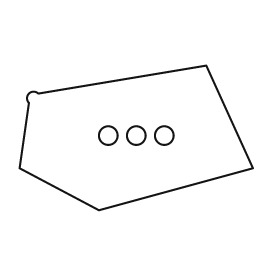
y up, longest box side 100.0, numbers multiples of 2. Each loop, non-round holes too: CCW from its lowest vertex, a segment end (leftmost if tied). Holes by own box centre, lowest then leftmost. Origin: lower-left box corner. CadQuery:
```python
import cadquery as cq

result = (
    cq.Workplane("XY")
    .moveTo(34.0, 0.0)
    .lineTo(100.0, 18.0)
    .lineTo(80.0, 62.0)
    .lineTo(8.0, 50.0)
    .threePointArc((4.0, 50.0), (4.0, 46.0))
    .lineTo(0.0, 18.0)
    .close()
    .moveTo(38.0, 32.0)
    .circle(4.0)
    .moveTo(50.0, 32.0)
    .circle(4.0)
    .moveTo(62.0, 32.0)
    .circle(4.0)
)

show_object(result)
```